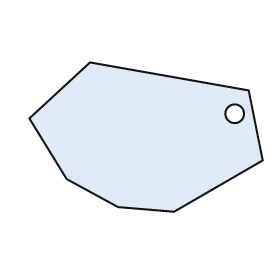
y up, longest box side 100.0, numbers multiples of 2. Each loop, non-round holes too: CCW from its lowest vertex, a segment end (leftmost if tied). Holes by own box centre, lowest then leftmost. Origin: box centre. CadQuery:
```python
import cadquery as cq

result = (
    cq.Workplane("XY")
    .moveTo(12.0, -32.0)
    .lineTo(50.0, -10.0)
    .lineTo(44.0, 20.0)
    .lineTo(-24.0, 32.0)
    .lineTo(-50.0, 8.0)
    .lineTo(-34.0, -18.0)
    .lineTo(-12.0, -30.0)
    .close()
    .moveTo(38.0, 10.0)
    .circle(4.0)
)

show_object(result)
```